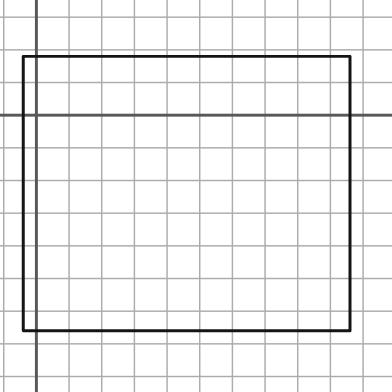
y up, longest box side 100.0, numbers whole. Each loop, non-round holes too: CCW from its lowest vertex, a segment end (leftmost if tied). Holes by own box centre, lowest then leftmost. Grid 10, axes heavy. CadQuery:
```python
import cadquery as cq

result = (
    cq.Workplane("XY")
    .moveTo(-4.0, -66.0)
    .lineTo(96.0, -66.0)
    .lineTo(96.0, 18.0)
    .lineTo(-4.0, 18.0)
    .close()
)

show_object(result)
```